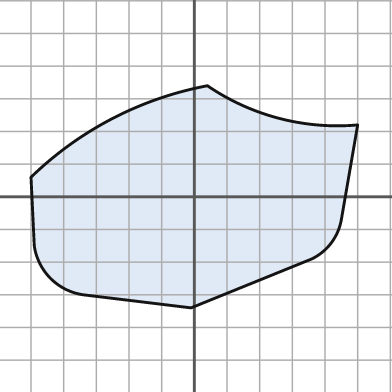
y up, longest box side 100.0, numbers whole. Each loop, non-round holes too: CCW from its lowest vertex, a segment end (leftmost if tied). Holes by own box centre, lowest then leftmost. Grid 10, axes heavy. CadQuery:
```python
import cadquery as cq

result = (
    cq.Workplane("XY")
    .moveTo(-1.0, -34.0)
    .lineTo(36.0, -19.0)
    .threePointArc((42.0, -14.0), (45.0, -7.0))
    .lineTo(50.0, 22.0)
    .threePointArc((26.0, 24.0), (4.0, 34.0))
    .threePointArc((-25.0, 24.0), (-50.0, 6.0))
    .lineTo(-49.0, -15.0)
    .threePointArc((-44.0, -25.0), (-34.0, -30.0))
    .close()
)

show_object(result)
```